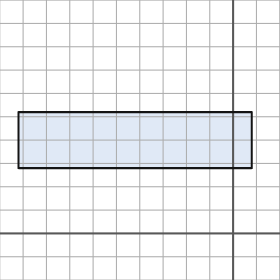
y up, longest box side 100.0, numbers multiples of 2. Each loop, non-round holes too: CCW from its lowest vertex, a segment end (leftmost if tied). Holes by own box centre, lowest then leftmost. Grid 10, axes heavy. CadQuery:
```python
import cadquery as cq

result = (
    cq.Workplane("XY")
    .moveTo(-92.0, 28.0)
    .lineTo(8.0, 28.0)
    .lineTo(8.0, 52.0)
    .lineTo(-92.0, 52.0)
    .close()
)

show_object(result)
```